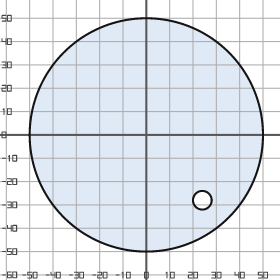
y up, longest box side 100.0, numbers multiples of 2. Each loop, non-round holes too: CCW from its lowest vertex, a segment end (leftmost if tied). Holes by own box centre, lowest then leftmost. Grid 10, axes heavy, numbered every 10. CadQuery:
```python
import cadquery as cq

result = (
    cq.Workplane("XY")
    .moveTo(0.0, 0.0)
    .circle(50.0)
    .moveTo(24.0, -28.0)
    .circle(4.0)
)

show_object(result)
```